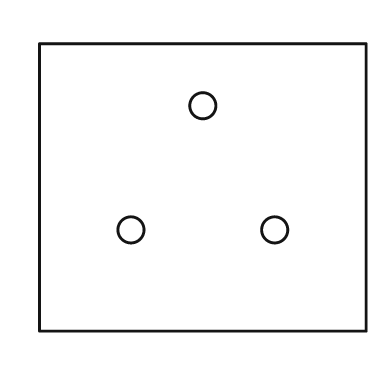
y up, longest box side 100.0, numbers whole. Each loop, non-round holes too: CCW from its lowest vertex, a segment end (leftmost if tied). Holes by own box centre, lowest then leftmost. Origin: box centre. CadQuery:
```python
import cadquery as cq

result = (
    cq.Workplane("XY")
    .moveTo(-50.0, -44.0)
    .lineTo(50.0, -44.0)
    .lineTo(50.0, 44.0)
    .lineTo(-50.0, 44.0)
    .close()
    .moveTo(-22.0, -13.0)
    .circle(4.0)
    .moveTo(22.0, -13.0)
    .circle(4.0)
    .moveTo(0.0, 25.0)
    .circle(4.0)
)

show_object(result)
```